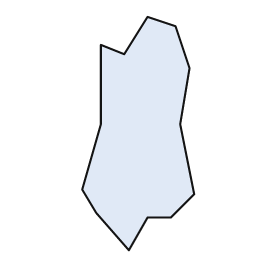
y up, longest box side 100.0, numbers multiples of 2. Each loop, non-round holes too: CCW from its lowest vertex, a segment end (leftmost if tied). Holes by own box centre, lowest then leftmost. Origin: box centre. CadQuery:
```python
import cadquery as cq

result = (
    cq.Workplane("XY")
    .moveTo(-4.0, -50.0)
    .lineTo(4.0, -36.0)
    .lineTo(14.0, -36.0)
    .lineTo(24.0, -26.0)
    .lineTo(18.0, 4.0)
    .lineTo(22.0, 28.0)
    .lineTo(16.0, 46.0)
    .lineTo(4.0, 50.0)
    .lineTo(-6.0, 34.0)
    .lineTo(-16.0, 38.0)
    .lineTo(-16.0, 4.0)
    .lineTo(-24.0, -24.0)
    .lineTo(-18.0, -34.0)
    .close()
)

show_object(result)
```